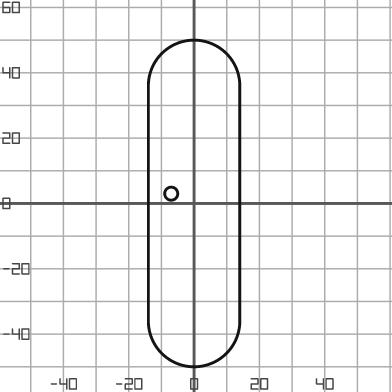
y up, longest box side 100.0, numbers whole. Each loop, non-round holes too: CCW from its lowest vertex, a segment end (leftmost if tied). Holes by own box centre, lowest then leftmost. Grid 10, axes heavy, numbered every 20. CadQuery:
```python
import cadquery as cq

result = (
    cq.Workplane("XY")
    .moveTo(-14.0, -36.0)
    .threePointArc((0.0, -50.0), (14.0, -36.0))
    .lineTo(14.0, 36.0)
    .threePointArc((0.0, 50.0), (-14.0, 36.0))
    .close()
    .moveTo(-7.0, 3.0)
    .circle(2.0)
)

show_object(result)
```